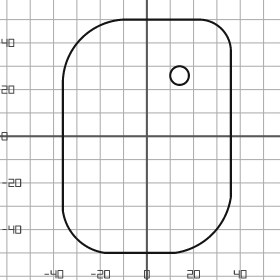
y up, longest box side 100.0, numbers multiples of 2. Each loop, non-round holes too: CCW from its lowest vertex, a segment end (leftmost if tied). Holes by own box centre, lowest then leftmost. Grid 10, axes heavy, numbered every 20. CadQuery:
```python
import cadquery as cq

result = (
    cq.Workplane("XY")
    .moveTo(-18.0, -50.0)
    .lineTo(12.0, -50.0)
    .threePointArc((28.0, -42.0), (36.0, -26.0))
    .lineTo(36.0, 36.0)
    .threePointArc((32.0, 46.0), (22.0, 50.0))
    .lineTo(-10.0, 50.0)
    .threePointArc((-28.0, 42.0), (-36.0, 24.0))
    .lineTo(-36.0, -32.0)
    .threePointArc((-30.0, -44.0), (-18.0, -50.0))
    .close()
    .moveTo(14.0, 26.0)
    .circle(4.0)
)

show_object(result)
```